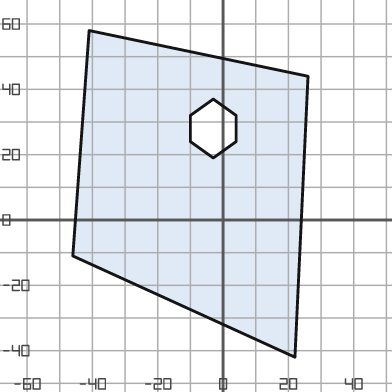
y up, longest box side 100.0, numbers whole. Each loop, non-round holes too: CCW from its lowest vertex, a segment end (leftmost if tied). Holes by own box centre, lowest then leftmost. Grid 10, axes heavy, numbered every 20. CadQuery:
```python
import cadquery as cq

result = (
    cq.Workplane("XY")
    .moveTo(22.0, -42.0)
    .lineTo(26.0, 44.0)
    .lineTo(-41.0, 58.0)
    .lineTo(-46.0, -11.0)
    .close()
    .moveTo(-3.0, 19.0)
    .lineTo(4.0, 24.0)
    .lineTo(4.0, 32.0)
    .lineTo(-3.0, 37.0)
    .lineTo(-10.0, 32.0)
    .lineTo(-10.0, 24.0)
    .close()
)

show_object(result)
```